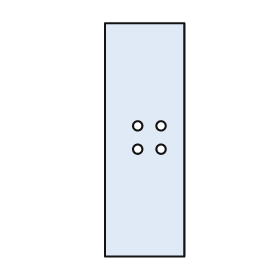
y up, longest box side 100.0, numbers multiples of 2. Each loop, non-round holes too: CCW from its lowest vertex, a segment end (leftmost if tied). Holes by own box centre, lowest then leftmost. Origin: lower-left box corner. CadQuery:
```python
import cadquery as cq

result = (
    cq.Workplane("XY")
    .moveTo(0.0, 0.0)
    .lineTo(34.0, 0.0)
    .lineTo(34.0, 100.0)
    .lineTo(0.0, 100.0)
    .close()
    .moveTo(14.0, 46.0)
    .circle(2.0)
    .moveTo(24.0, 46.0)
    .circle(2.0)
    .moveTo(14.0, 56.0)
    .circle(2.0)
    .moveTo(24.0, 56.0)
    .circle(2.0)
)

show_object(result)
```